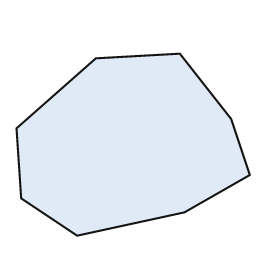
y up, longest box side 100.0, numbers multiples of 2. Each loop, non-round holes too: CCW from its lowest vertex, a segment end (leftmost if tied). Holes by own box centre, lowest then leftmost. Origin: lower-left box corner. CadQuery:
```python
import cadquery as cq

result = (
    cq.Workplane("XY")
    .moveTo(26.0, 0.0)
    .lineTo(72.0, 10.0)
    .lineTo(100.0, 26.0)
    .lineTo(92.0, 50.0)
    .lineTo(70.0, 78.0)
    .lineTo(34.0, 76.0)
    .lineTo(0.0, 46.0)
    .lineTo(2.0, 16.0)
    .close()
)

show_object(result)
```